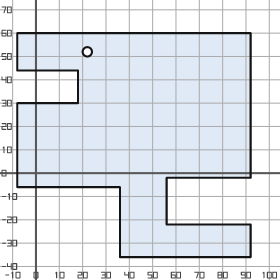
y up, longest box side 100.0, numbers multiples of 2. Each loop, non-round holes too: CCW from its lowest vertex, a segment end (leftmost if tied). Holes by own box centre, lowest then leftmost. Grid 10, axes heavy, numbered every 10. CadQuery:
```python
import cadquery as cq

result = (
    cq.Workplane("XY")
    .moveTo(36.0, -36.0)
    .lineTo(92.0, -36.0)
    .lineTo(92.0, -22.0)
    .lineTo(56.0, -22.0)
    .lineTo(56.0, -2.0)
    .lineTo(92.0, -2.0)
    .lineTo(92.0, 60.0)
    .lineTo(-8.0, 60.0)
    .lineTo(-8.0, 44.0)
    .lineTo(18.0, 44.0)
    .lineTo(18.0, 30.0)
    .lineTo(-8.0, 30.0)
    .lineTo(-8.0, -6.0)
    .lineTo(36.0, -6.0)
    .close()
    .moveTo(22.0, 52.0)
    .circle(2.0)
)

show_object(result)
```